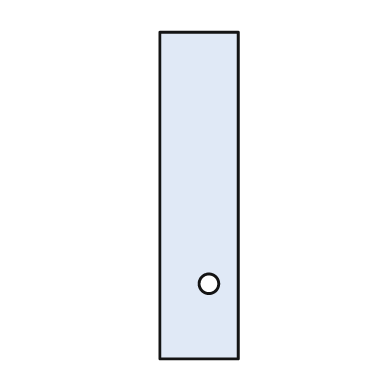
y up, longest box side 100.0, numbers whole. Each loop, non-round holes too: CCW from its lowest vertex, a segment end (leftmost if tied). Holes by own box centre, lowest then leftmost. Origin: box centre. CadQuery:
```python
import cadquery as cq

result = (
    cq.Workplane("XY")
    .moveTo(-12.0, -50.0)
    .lineTo(12.0, -50.0)
    .lineTo(12.0, 50.0)
    .lineTo(-12.0, 50.0)
    .close()
    .moveTo(3.0, -27.0)
    .circle(3.0)
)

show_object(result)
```